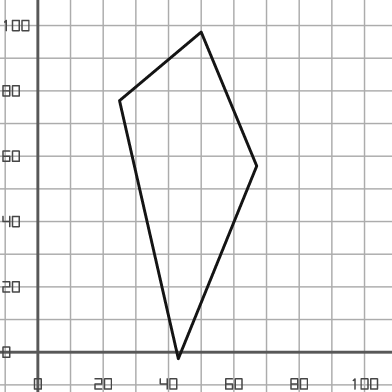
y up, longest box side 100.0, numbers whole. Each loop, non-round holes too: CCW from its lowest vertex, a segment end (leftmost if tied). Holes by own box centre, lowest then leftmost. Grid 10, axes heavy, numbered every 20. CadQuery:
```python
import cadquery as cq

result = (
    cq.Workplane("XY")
    .moveTo(43.0, -2.0)
    .lineTo(67.0, 57.0)
    .lineTo(50.0, 98.0)
    .lineTo(25.0, 77.0)
    .close()
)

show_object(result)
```